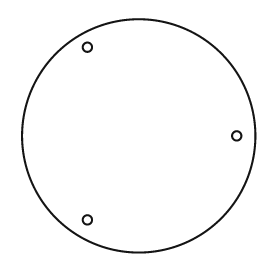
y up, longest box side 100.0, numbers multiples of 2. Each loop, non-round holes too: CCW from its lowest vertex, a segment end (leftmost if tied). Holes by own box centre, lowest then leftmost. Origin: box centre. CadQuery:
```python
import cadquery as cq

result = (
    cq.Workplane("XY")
    .moveTo(0.0, 0.0)
    .circle(50.0)
    .moveTo(-22.0, -36.0)
    .circle(2.0)
    .moveTo(42.0, 0.0)
    .circle(2.0)
    .moveTo(-22.0, 38.0)
    .circle(2.0)
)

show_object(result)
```